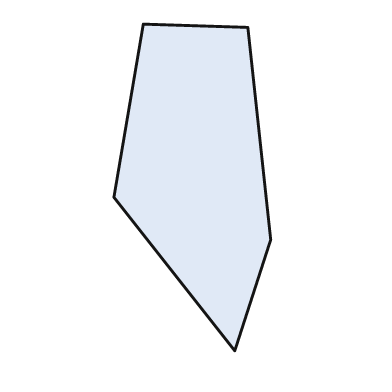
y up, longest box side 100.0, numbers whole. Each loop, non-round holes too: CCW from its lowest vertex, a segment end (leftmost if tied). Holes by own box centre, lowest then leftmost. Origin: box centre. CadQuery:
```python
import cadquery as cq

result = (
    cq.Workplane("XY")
    .moveTo(13.0, -50.0)
    .lineTo(24.0, -16.0)
    .lineTo(17.0, 49.0)
    .lineTo(-15.0, 50.0)
    .lineTo(-24.0, -3.0)
    .close()
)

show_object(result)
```